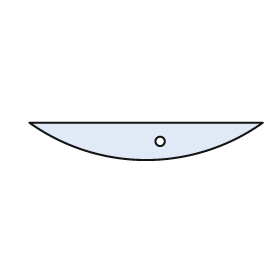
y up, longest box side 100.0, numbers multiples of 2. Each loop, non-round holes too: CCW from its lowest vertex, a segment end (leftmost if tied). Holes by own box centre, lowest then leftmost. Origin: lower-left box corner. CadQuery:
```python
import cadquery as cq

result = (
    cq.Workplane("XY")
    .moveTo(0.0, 16.0)
    .threePointArc((50.0, 0.0), (100.0, 16.0))
    .close()
    .moveTo(56.0, 8.0)
    .circle(2.0)
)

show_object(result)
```